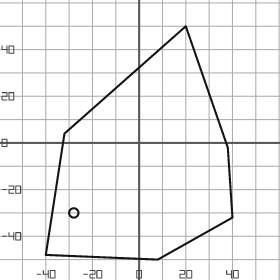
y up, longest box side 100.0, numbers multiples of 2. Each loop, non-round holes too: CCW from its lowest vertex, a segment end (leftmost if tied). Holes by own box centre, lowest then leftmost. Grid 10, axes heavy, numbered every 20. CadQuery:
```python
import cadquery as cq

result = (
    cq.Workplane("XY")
    .moveTo(8.0, -50.0)
    .lineTo(40.0, -32.0)
    .lineTo(38.0, -2.0)
    .lineTo(20.0, 50.0)
    .lineTo(-32.0, 4.0)
    .lineTo(-40.0, -48.0)
    .close()
    .moveTo(-28.0, -30.0)
    .circle(2.0)
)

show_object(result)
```